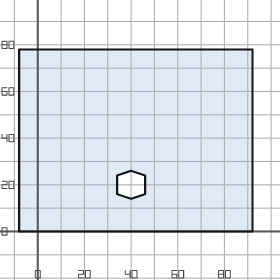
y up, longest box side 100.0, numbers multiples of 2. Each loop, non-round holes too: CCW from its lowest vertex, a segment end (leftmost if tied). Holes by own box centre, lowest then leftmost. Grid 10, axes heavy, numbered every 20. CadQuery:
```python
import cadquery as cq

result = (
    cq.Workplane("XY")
    .moveTo(-8.0, 0.0)
    .lineTo(92.0, 0.0)
    .lineTo(92.0, 78.0)
    .lineTo(-8.0, 78.0)
    .close()
    .moveTo(40.0, 14.0)
    .lineTo(46.0, 16.0)
    .lineTo(46.0, 24.0)
    .lineTo(40.0, 26.0)
    .lineTo(34.0, 24.0)
    .lineTo(34.0, 16.0)
    .close()
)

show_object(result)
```